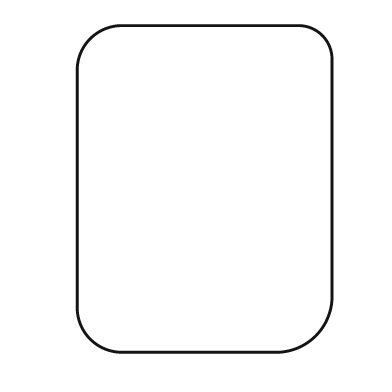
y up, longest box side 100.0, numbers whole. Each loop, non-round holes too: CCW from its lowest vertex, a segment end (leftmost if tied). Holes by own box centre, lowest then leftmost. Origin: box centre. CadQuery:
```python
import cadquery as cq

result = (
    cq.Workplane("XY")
    .moveTo(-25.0, -50.0)
    .lineTo(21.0, -50.0)
    .threePointArc((34.0, -45.0), (39.0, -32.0))
    .lineTo(39.0, 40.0)
    .threePointArc((36.0, 47.0), (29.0, 50.0))
    .lineTo(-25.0, 50.0)
    .threePointArc((-35.0, 46.0), (-39.0, 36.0))
    .lineTo(-39.0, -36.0)
    .threePointArc((-35.0, -46.0), (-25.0, -50.0))
    .close()
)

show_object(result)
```